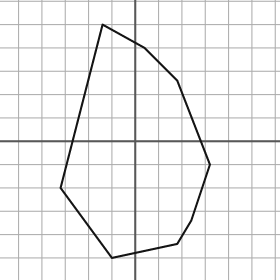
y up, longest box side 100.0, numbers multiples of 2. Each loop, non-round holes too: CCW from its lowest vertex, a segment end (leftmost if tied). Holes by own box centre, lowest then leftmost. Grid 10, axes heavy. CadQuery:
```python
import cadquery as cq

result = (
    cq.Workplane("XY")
    .moveTo(-10.0, -50.0)
    .lineTo(18.0, -44.0)
    .lineTo(24.0, -34.0)
    .lineTo(32.0, -10.0)
    .lineTo(18.0, 26.0)
    .lineTo(4.0, 40.0)
    .lineTo(-14.0, 50.0)
    .lineTo(-32.0, -20.0)
    .close()
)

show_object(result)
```